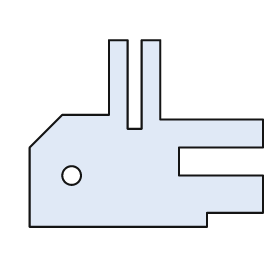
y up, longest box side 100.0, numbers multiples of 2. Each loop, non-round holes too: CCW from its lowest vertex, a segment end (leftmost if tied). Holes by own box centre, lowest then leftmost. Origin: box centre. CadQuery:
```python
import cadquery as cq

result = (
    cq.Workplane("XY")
    .moveTo(-50.0, -40.0)
    .lineTo(26.0, -40.0)
    .lineTo(26.0, -34.0)
    .lineTo(50.0, -34.0)
    .lineTo(50.0, -18.0)
    .lineTo(14.0, -18.0)
    .lineTo(14.0, -6.0)
    .lineTo(50.0, -6.0)
    .lineTo(50.0, 6.0)
    .lineTo(6.0, 6.0)
    .lineTo(6.0, 40.0)
    .lineTo(-2.0, 40.0)
    .lineTo(-2.0, 2.0)
    .lineTo(-8.0, 2.0)
    .lineTo(-8.0, 40.0)
    .lineTo(-16.0, 40.0)
    .lineTo(-16.0, 8.0)
    .lineTo(-36.0, 8.0)
    .lineTo(-50.0, -6.0)
    .close()
    .moveTo(-32.0, -18.0)
    .circle(4.0)
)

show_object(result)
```